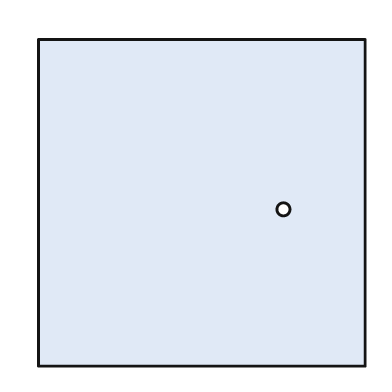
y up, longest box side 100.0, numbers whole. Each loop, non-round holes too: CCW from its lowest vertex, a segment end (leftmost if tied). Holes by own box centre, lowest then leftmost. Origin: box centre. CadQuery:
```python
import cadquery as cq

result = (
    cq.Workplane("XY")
    .moveTo(-50.0, -50.0)
    .lineTo(50.0, -50.0)
    .lineTo(50.0, 50.0)
    .lineTo(-50.0, 50.0)
    .close()
    .moveTo(25.0, -2.0)
    .circle(2.0)
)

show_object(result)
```